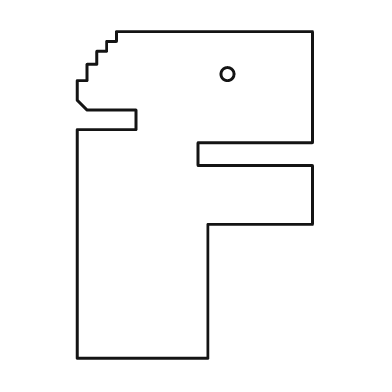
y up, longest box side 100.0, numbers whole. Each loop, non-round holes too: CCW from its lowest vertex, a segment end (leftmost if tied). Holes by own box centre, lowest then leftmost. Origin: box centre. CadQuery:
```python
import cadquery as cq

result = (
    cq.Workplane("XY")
    .moveTo(-36.0, -50.0)
    .lineTo(4.0, -50.0)
    .lineTo(4.0, -9.0)
    .lineTo(36.0, -9.0)
    .lineTo(36.0, 9.0)
    .lineTo(1.0, 9.0)
    .lineTo(1.0, 16.0)
    .lineTo(36.0, 16.0)
    .lineTo(36.0, 50.0)
    .lineTo(-24.0, 50.0)
    .lineTo(-24.0, 47.0)
    .lineTo(-27.0, 47.0)
    .lineTo(-27.0, 44.0)
    .lineTo(-30.0, 44.0)
    .lineTo(-30.0, 40.0)
    .lineTo(-33.0, 40.0)
    .lineTo(-33.0, 35.0)
    .lineTo(-36.0, 35.0)
    .lineTo(-36.0, 29.0)
    .lineTo(-33.0, 26.0)
    .lineTo(-18.0, 26.0)
    .lineTo(-18.0, 20.0)
    .lineTo(-36.0, 20.0)
    .close()
    .moveTo(10.0, 37.0)
    .circle(2.0)
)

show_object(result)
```